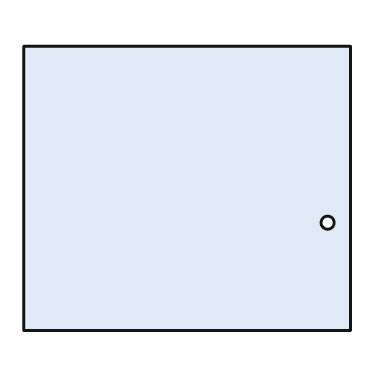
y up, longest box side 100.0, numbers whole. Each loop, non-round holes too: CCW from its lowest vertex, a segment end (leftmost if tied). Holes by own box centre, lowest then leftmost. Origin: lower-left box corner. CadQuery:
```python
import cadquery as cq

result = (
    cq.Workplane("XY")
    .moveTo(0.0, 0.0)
    .lineTo(100.0, 0.0)
    .lineTo(100.0, 87.0)
    .lineTo(0.0, 87.0)
    .close()
    .moveTo(93.0, 33.0)
    .circle(2.0)
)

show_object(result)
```